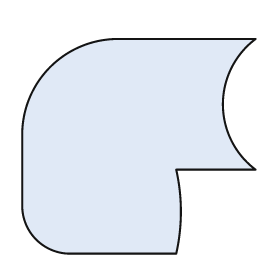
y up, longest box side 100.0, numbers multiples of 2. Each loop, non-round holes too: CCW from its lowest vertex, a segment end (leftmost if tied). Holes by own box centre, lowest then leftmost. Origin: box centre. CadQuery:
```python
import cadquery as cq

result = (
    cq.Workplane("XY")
    .moveTo(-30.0, -46.0)
    .lineTo(16.0, -46.0)
    .threePointArc((18.0, -28.0), (16.0, -10.0))
    .lineTo(50.0, -10.0)
    .threePointArc((36.0, 18.0), (50.0, 46.0))
    .lineTo(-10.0, 46.0)
    .threePointArc((-38.0, 34.0), (-50.0, 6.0))
    .lineTo(-50.0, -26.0)
    .threePointArc((-44.0, -40.0), (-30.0, -46.0))
    .close()
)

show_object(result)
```